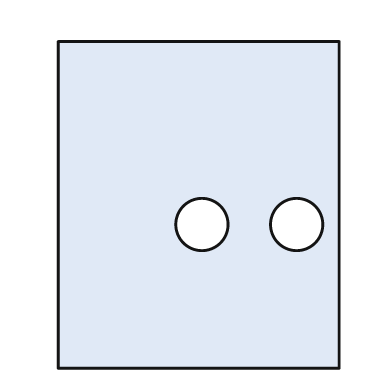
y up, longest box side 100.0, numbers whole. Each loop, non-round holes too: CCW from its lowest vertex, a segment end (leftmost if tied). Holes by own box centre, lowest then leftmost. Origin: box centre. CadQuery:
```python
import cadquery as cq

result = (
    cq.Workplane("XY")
    .moveTo(-43.0, -50.0)
    .lineTo(43.0, -50.0)
    .lineTo(43.0, 50.0)
    .lineTo(-43.0, 50.0)
    .close()
    .moveTo(1.0, -6.0)
    .circle(8.0)
    .moveTo(30.0, -6.0)
    .circle(8.0)
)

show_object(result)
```